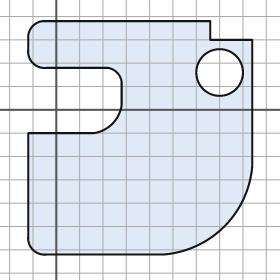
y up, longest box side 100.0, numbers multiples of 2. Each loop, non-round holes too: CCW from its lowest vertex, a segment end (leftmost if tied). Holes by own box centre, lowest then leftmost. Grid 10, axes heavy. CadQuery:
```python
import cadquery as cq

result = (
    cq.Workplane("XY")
    .moveTo(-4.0, -62.0)
    .lineTo(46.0, -62.0)
    .threePointArc((72.0, -50.0), (84.0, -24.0))
    .lineTo(84.0, 30.0)
    .lineTo(66.0, 30.0)
    .lineTo(66.0, 38.0)
    .lineTo(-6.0, 38.0)
    .threePointArc((-10.0, 36.0), (-12.0, 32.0))
    .lineTo(-12.0, 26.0)
    .threePointArc((-10.0, 20.0), (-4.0, 18.0))
    .lineTo(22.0, 18.0)
    .threePointArc((26.0, 16.0), (28.0, 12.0))
    .lineTo(28.0, 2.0)
    .threePointArc((24.0, -6.0), (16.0, -10.0))
    .lineTo(-12.0, -10.0)
    .lineTo(-12.0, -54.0)
    .threePointArc((-10.0, -60.0), (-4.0, -62.0))
    .close()
    .moveTo(70.0, 16.0)
    .circle(10.0)
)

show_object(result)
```